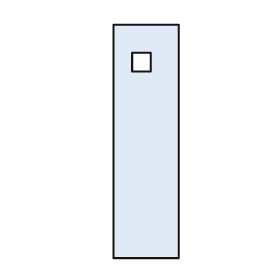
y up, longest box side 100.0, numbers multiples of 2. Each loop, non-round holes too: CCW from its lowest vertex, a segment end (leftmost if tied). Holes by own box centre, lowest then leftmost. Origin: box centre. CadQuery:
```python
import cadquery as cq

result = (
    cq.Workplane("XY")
    .moveTo(-14.0, -50.0)
    .lineTo(14.0, -50.0)
    .lineTo(14.0, 50.0)
    .lineTo(-14.0, 50.0)
    .close()
    .moveTo(-6.0, 30.0)
    .lineTo(2.0, 30.0)
    .lineTo(2.0, 38.0)
    .lineTo(-6.0, 38.0)
    .close()
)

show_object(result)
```